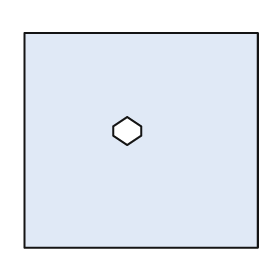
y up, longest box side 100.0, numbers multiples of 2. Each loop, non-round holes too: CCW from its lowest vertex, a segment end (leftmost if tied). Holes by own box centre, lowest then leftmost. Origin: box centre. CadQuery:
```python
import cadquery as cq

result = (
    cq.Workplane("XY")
    .moveTo(-50.0, -46.0)
    .lineTo(50.0, -46.0)
    .lineTo(50.0, 46.0)
    .lineTo(-50.0, 46.0)
    .close()
    .moveTo(-6.0, -2.0)
    .lineTo(0.0, 2.0)
    .lineTo(0.0, 6.0)
    .lineTo(-6.0, 10.0)
    .lineTo(-12.0, 6.0)
    .lineTo(-12.0, 2.0)
    .close()
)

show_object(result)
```